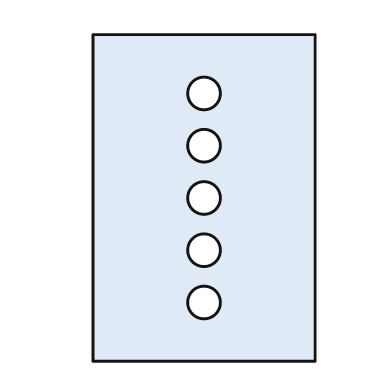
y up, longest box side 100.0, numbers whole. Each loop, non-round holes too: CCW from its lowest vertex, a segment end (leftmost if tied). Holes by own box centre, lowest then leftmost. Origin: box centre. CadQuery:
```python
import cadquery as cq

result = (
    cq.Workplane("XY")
    .moveTo(-34.0, -50.0)
    .lineTo(34.0, -50.0)
    .lineTo(34.0, 50.0)
    .lineTo(-34.0, 50.0)
    .close()
    .moveTo(0.0, -32.0)
    .circle(5.0)
    .moveTo(0.0, -16.0)
    .circle(5.0)
    .moveTo(0.0, 0.0)
    .circle(5.0)
    .moveTo(0.0, 16.0)
    .circle(5.0)
    .moveTo(0.0, 32.0)
    .circle(5.0)
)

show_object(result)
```